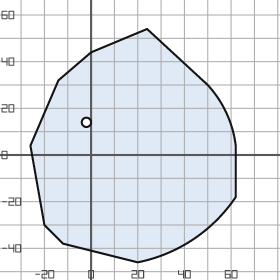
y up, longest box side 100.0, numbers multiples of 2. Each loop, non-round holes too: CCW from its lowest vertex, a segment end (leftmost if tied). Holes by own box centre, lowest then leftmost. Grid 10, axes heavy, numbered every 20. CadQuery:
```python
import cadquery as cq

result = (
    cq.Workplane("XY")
    .moveTo(20.0, -46.0)
    .threePointArc((44.0, -36.0), (62.0, -18.0))
    .lineTo(62.0, 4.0)
    .threePointArc((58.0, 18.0), (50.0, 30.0))
    .lineTo(24.0, 54.0)
    .lineTo(0.0, 44.0)
    .lineTo(-14.0, 32.0)
    .lineTo(-26.0, 4.0)
    .lineTo(-20.0, -30.0)
    .lineTo(-12.0, -38.0)
    .close()
    .moveTo(-2.0, 14.0)
    .circle(2.0)
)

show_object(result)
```